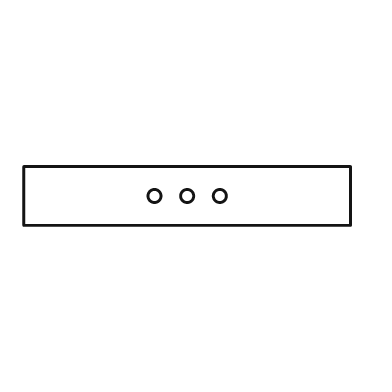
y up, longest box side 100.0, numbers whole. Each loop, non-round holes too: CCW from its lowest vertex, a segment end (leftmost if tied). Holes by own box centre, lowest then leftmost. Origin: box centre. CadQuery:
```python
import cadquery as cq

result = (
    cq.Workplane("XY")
    .moveTo(-50.0, -9.0)
    .lineTo(50.0, -9.0)
    .lineTo(50.0, 9.0)
    .lineTo(-50.0, 9.0)
    .close()
    .moveTo(-10.0, 0.0)
    .circle(2.0)
    .moveTo(0.0, 0.0)
    .circle(2.0)
    .moveTo(10.0, 0.0)
    .circle(2.0)
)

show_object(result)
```